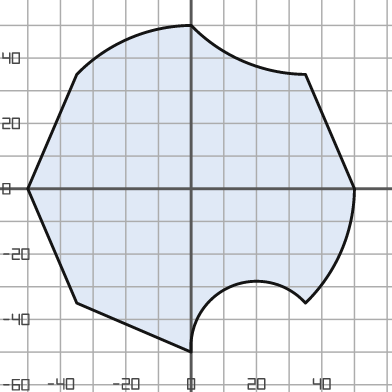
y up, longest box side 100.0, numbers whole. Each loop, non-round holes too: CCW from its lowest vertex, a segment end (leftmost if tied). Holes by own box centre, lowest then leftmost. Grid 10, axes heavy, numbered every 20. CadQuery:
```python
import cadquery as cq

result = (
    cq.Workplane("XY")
    .moveTo(0.0, -50.0)
    .threePointArc((12.0, -30.0), (35.0, -35.0))
    .threePointArc((46.0, -19.0), (50.0, 0.0))
    .lineTo(35.0, 35.0)
    .threePointArc((16.0, 39.0), (0.0, 50.0))
    .threePointArc((-19.0, 46.0), (-35.0, 35.0))
    .lineTo(-50.0, 0.0)
    .lineTo(-35.0, -35.0)
    .close()
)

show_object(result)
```